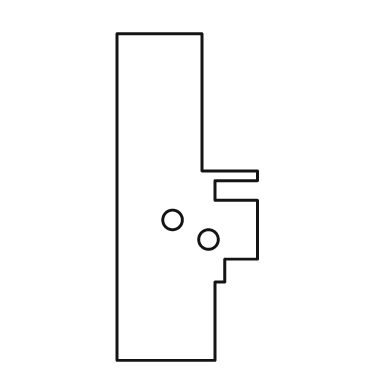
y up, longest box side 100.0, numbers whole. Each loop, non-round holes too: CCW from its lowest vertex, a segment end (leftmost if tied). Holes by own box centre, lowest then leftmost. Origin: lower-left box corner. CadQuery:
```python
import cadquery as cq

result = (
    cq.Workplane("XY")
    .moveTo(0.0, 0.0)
    .lineTo(30.0, 0.0)
    .lineTo(30.0, 24.0)
    .lineTo(33.0, 24.0)
    .lineTo(33.0, 31.0)
    .lineTo(43.0, 31.0)
    .lineTo(43.0, 49.0)
    .lineTo(30.0, 49.0)
    .lineTo(30.0, 55.0)
    .lineTo(43.0, 55.0)
    .lineTo(43.0, 58.0)
    .lineTo(26.0, 58.0)
    .lineTo(26.0, 100.0)
    .lineTo(0.0, 100.0)
    .close()
    .moveTo(28.0, 37.0)
    .circle(3.0)
    .moveTo(17.0, 43.0)
    .circle(3.0)
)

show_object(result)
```